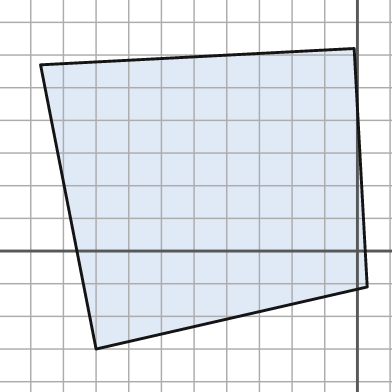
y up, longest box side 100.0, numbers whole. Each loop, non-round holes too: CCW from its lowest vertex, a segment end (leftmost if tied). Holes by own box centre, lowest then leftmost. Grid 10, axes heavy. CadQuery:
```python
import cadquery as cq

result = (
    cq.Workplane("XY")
    .moveTo(-80.0, -30.0)
    .lineTo(3.0, -11.0)
    .lineTo(-1.0, 62.0)
    .lineTo(-97.0, 57.0)
    .close()
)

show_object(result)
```